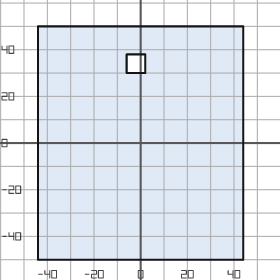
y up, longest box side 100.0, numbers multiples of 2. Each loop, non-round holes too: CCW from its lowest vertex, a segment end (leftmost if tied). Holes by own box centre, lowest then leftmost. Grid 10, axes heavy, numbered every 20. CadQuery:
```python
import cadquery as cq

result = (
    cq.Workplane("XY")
    .moveTo(-44.0, -50.0)
    .lineTo(44.0, -50.0)
    .lineTo(44.0, 50.0)
    .lineTo(-44.0, 50.0)
    .close()
    .moveTo(-6.0, 30.0)
    .lineTo(2.0, 30.0)
    .lineTo(2.0, 38.0)
    .lineTo(-6.0, 38.0)
    .close()
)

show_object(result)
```